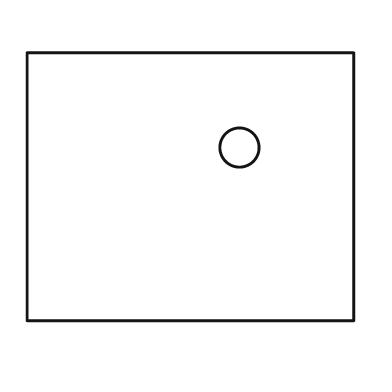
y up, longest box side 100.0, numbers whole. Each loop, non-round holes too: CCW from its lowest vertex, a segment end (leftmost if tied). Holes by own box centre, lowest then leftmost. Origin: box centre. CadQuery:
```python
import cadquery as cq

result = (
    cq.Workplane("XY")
    .moveTo(-50.0, -41.0)
    .lineTo(50.0, -41.0)
    .lineTo(50.0, 41.0)
    .lineTo(-50.0, 41.0)
    .close()
    .moveTo(15.0, 12.0)
    .circle(6.0)
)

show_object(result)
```